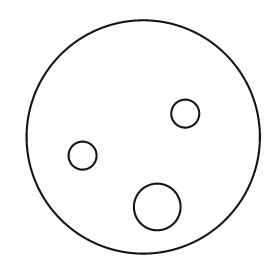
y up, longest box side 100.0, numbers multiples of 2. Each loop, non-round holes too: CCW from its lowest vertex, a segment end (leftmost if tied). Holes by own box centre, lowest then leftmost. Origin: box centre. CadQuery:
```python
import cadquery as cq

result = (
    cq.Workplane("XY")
    .moveTo(0.0, 0.0)
    .circle(50.0)
    .moveTo(6.0, -30.0)
    .circle(10.0)
    .moveTo(-26.0, -8.0)
    .circle(6.0)
    .moveTo(18.0, 10.0)
    .circle(6.0)
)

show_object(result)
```